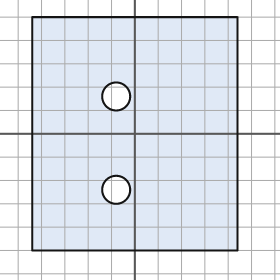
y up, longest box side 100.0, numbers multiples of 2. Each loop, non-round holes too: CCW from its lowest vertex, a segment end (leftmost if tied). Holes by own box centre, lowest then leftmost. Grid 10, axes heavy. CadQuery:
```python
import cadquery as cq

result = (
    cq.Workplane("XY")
    .moveTo(-44.0, -50.0)
    .lineTo(44.0, -50.0)
    .lineTo(44.0, 50.0)
    .lineTo(-44.0, 50.0)
    .close()
    .moveTo(-8.0, -24.0)
    .circle(6.0)
    .moveTo(-8.0, 16.0)
    .circle(6.0)
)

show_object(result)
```